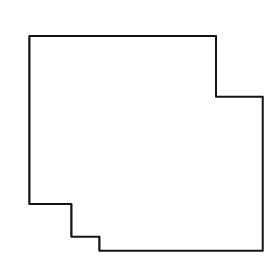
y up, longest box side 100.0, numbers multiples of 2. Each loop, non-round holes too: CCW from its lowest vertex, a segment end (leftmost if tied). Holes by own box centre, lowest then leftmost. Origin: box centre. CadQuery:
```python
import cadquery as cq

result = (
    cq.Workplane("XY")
    .moveTo(-20.0, -46.0)
    .lineTo(50.0, -46.0)
    .lineTo(50.0, 20.0)
    .lineTo(30.0, 20.0)
    .lineTo(30.0, 46.0)
    .lineTo(-50.0, 46.0)
    .lineTo(-50.0, -26.0)
    .lineTo(-32.0, -26.0)
    .lineTo(-32.0, -40.0)
    .lineTo(-20.0, -40.0)
    .close()
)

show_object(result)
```